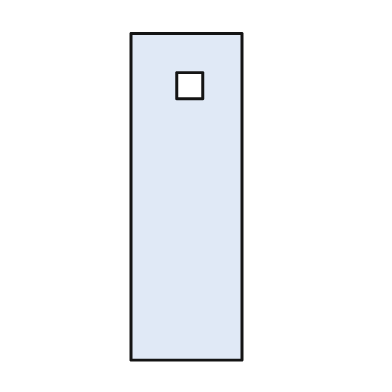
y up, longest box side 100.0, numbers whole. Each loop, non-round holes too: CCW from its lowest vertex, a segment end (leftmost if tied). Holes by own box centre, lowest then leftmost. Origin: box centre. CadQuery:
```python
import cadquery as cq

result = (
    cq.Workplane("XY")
    .moveTo(-17.0, -50.0)
    .lineTo(17.0, -50.0)
    .lineTo(17.0, 50.0)
    .lineTo(-17.0, 50.0)
    .close()
    .moveTo(-3.0, 30.0)
    .lineTo(5.0, 30.0)
    .lineTo(5.0, 38.0)
    .lineTo(-3.0, 38.0)
    .close()
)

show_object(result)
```